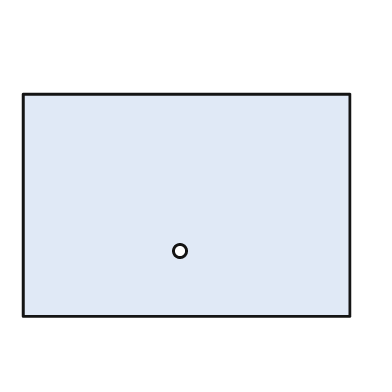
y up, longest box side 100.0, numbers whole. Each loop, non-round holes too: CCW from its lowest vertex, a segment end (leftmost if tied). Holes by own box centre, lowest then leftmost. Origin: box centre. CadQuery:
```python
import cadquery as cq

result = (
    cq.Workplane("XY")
    .moveTo(-50.0, -34.0)
    .lineTo(50.0, -34.0)
    .lineTo(50.0, 34.0)
    .lineTo(-50.0, 34.0)
    .close()
    .moveTo(-2.0, -14.0)
    .circle(2.0)
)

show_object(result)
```